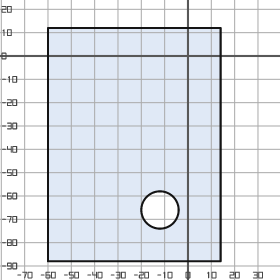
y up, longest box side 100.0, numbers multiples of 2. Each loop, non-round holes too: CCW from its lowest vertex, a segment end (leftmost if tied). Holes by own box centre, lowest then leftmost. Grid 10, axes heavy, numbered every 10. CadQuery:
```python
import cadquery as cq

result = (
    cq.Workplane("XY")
    .moveTo(-60.0, -88.0)
    .lineTo(14.0, -88.0)
    .lineTo(14.0, 12.0)
    .lineTo(-60.0, 12.0)
    .close()
    .moveTo(-12.0, -66.0)
    .circle(8.0)
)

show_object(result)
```